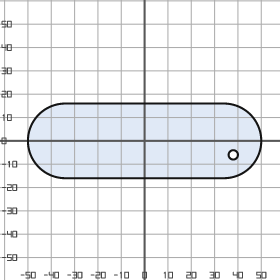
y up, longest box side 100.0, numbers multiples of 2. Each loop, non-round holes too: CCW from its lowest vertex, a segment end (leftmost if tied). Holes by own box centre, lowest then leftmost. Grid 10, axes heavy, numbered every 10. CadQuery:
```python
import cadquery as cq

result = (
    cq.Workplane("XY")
    .moveTo(-34.0, -16.0)
    .lineTo(34.0, -16.0)
    .threePointArc((50.0, 0.0), (34.0, 16.0))
    .lineTo(-34.0, 16.0)
    .threePointArc((-50.0, 0.0), (-34.0, -16.0))
    .close()
    .moveTo(38.0, -6.0)
    .circle(2.0)
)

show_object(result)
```